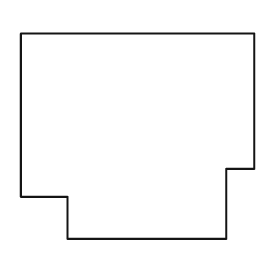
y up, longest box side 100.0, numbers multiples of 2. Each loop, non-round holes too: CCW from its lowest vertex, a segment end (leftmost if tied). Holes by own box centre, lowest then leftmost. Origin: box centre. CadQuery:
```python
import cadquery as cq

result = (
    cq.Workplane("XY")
    .moveTo(-30.0, -44.0)
    .lineTo(38.0, -44.0)
    .lineTo(38.0, -14.0)
    .lineTo(50.0, -14.0)
    .lineTo(50.0, 44.0)
    .lineTo(-50.0, 44.0)
    .lineTo(-50.0, -26.0)
    .lineTo(-30.0, -26.0)
    .close()
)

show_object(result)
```